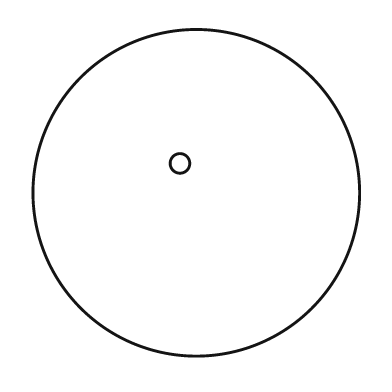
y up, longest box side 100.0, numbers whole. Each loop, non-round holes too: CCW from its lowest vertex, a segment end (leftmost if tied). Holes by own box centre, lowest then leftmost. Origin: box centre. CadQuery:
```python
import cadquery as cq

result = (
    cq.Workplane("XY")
    .moveTo(0.0, 0.0)
    .circle(50.0)
    .moveTo(-5.0, 9.0)
    .circle(3.0)
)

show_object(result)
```